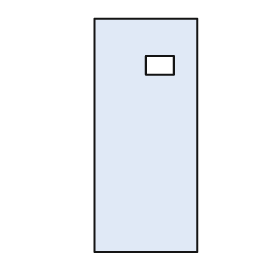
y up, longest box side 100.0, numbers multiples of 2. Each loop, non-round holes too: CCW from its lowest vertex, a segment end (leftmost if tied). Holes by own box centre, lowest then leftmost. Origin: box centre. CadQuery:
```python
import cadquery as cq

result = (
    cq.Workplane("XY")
    .moveTo(-22.0, -50.0)
    .lineTo(22.0, -50.0)
    .lineTo(22.0, 50.0)
    .lineTo(-22.0, 50.0)
    .close()
    .moveTo(0.0, 26.0)
    .lineTo(12.0, 26.0)
    .lineTo(12.0, 34.0)
    .lineTo(0.0, 34.0)
    .close()
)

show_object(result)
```